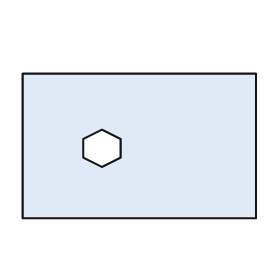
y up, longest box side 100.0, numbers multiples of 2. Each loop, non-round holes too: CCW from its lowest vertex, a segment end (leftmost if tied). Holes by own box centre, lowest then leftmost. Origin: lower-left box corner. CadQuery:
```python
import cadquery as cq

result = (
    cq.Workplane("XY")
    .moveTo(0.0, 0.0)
    .lineTo(100.0, 0.0)
    .lineTo(100.0, 62.0)
    .lineTo(0.0, 62.0)
    .close()
    .moveTo(34.0, 22.0)
    .lineTo(42.0, 26.0)
    .lineTo(42.0, 34.0)
    .lineTo(34.0, 38.0)
    .lineTo(26.0, 34.0)
    .lineTo(26.0, 26.0)
    .close()
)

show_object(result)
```